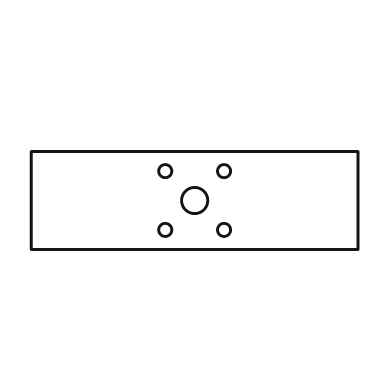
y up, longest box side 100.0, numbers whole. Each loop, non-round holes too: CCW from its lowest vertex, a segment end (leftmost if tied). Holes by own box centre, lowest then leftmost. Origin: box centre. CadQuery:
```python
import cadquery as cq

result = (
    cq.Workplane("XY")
    .moveTo(-50.0, -15.0)
    .lineTo(50.0, -15.0)
    .lineTo(50.0, 15.0)
    .lineTo(-50.0, 15.0)
    .close()
    .moveTo(-9.0, -9.0)
    .circle(2.0)
    .moveTo(9.0, -9.0)
    .circle(2.0)
    .moveTo(0.0, 0.0)
    .circle(4.0)
    .moveTo(-9.0, 9.0)
    .circle(2.0)
    .moveTo(9.0, 9.0)
    .circle(2.0)
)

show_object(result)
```